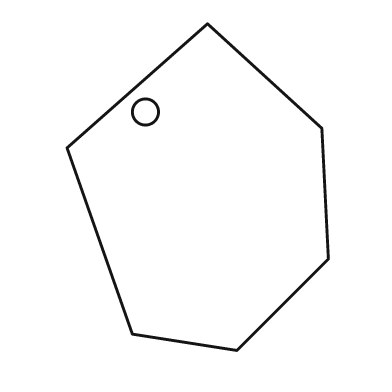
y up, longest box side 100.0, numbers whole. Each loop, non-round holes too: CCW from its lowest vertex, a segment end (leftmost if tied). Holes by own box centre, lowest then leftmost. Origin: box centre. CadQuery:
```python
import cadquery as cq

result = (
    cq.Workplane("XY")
    .moveTo(12.0, -50.0)
    .lineTo(40.0, -22.0)
    .lineTo(38.0, 18.0)
    .lineTo(3.0, 50.0)
    .lineTo(-40.0, 12.0)
    .lineTo(-20.0, -45.0)
    .close()
    .moveTo(-16.0, 23.0)
    .circle(4.0)
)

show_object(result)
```